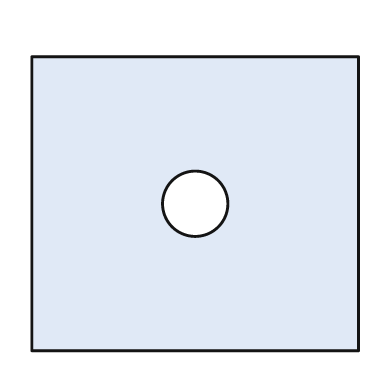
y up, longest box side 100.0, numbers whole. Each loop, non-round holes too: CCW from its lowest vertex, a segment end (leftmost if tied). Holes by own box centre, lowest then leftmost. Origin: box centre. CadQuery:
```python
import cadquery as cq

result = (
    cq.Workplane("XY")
    .moveTo(-50.0, -45.0)
    .lineTo(50.0, -45.0)
    .lineTo(50.0, 45.0)
    .lineTo(-50.0, 45.0)
    .close()
    .moveTo(0.0, 0.0)
    .circle(10.0)
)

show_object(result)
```